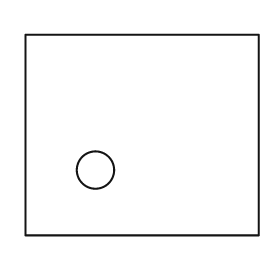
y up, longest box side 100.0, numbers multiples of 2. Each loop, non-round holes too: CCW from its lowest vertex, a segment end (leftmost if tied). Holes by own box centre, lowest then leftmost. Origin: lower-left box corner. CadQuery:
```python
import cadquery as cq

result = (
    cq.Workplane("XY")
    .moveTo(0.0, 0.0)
    .lineTo(100.0, 0.0)
    .lineTo(100.0, 86.0)
    .lineTo(0.0, 86.0)
    .close()
    .moveTo(30.0, 28.0)
    .circle(8.0)
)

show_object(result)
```